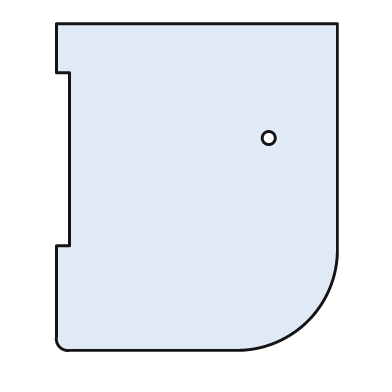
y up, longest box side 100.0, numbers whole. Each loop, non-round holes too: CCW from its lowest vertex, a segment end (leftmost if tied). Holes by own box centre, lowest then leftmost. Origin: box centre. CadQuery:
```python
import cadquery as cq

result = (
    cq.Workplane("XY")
    .moveTo(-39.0, -50.0)
    .lineTo(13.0, -50.0)
    .threePointArc((34.0, -41.0), (43.0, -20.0))
    .lineTo(43.0, 50.0)
    .lineTo(-43.0, 50.0)
    .lineTo(-43.0, 35.0)
    .lineTo(-39.0, 35.0)
    .lineTo(-39.0, -18.0)
    .lineTo(-43.0, -18.0)
    .lineTo(-43.0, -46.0)
    .threePointArc((-42.0, -49.0), (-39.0, -50.0))
    .close()
    .moveTo(22.0, 15.0)
    .circle(2.0)
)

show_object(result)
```